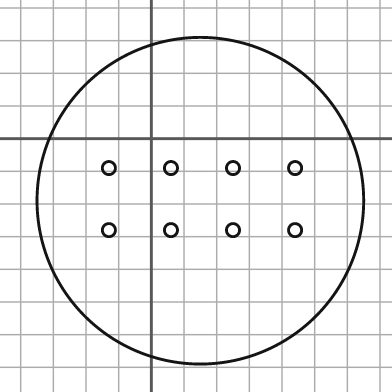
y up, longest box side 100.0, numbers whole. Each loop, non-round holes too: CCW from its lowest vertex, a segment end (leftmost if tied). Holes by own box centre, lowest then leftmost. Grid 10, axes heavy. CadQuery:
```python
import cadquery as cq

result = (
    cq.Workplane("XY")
    .moveTo(15.0, -19.0)
    .circle(50.0)
    .moveTo(-13.0, -28.0)
    .circle(2.0)
    .moveTo(6.0, -28.0)
    .circle(2.0)
    .moveTo(25.0, -28.0)
    .circle(2.0)
    .moveTo(44.0, -28.0)
    .circle(2.0)
    .moveTo(-13.0, -9.0)
    .circle(2.0)
    .moveTo(6.0, -9.0)
    .circle(2.0)
    .moveTo(25.0, -9.0)
    .circle(2.0)
    .moveTo(44.0, -9.0)
    .circle(2.0)
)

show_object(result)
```